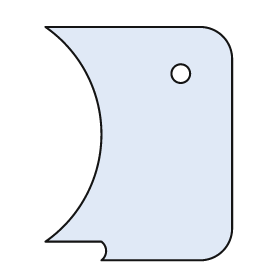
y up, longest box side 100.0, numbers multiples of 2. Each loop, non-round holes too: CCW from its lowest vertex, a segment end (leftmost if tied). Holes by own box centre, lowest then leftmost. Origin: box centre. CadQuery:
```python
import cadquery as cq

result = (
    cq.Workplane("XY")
    .moveTo(-16.0, -50.0)
    .lineTo(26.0, -50.0)
    .threePointArc((36.0, -46.0), (40.0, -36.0))
    .lineTo(40.0, 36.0)
    .threePointArc((36.0, 46.0), (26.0, 50.0))
    .lineTo(-40.0, 50.0)
    .threePointArc((-16.0, 4.0), (-40.0, -42.0))
    .lineTo(-16.0, -42.0)
    .threePointArc((-14.0, -46.0), (-16.0, -50.0))
    .close()
    .moveTo(18.0, 30.0)
    .circle(4.0)
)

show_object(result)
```